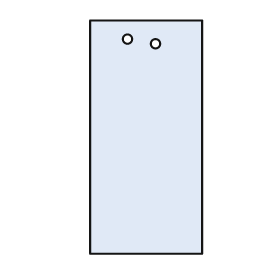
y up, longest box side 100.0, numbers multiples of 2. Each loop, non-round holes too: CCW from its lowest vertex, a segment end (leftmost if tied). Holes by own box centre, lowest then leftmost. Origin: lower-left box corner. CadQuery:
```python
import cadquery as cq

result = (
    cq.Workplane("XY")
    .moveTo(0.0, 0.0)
    .lineTo(48.0, 0.0)
    .lineTo(48.0, 100.0)
    .lineTo(0.0, 100.0)
    .close()
    .moveTo(28.0, 90.0)
    .circle(2.0)
    .moveTo(16.0, 92.0)
    .circle(2.0)
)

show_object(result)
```